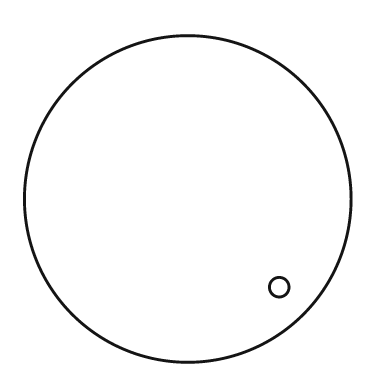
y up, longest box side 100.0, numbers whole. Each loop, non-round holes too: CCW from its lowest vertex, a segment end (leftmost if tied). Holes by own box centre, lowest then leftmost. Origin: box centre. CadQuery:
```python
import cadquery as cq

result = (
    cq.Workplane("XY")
    .moveTo(0.0, 0.0)
    .circle(50.0)
    .moveTo(28.0, -27.0)
    .circle(3.0)
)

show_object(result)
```